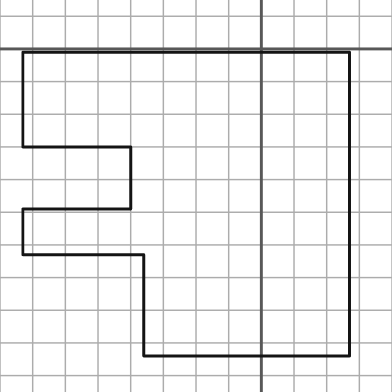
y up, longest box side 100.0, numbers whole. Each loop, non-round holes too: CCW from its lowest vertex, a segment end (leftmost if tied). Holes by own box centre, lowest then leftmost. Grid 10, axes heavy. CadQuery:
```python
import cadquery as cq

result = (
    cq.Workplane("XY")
    .moveTo(-36.0, -94.0)
    .lineTo(27.0, -94.0)
    .lineTo(27.0, -1.0)
    .lineTo(-73.0, -1.0)
    .lineTo(-73.0, -30.0)
    .lineTo(-40.0, -30.0)
    .lineTo(-40.0, -49.0)
    .lineTo(-73.0, -49.0)
    .lineTo(-73.0, -63.0)
    .lineTo(-36.0, -63.0)
    .close()
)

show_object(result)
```